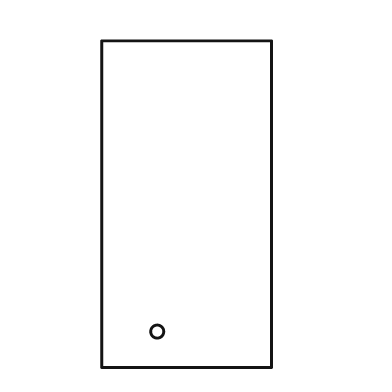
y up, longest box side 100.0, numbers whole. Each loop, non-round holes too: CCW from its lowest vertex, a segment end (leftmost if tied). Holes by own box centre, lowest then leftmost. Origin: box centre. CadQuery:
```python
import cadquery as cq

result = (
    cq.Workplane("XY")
    .moveTo(-26.0, -50.0)
    .lineTo(26.0, -50.0)
    .lineTo(26.0, 50.0)
    .lineTo(-26.0, 50.0)
    .close()
    .moveTo(-9.0, -39.0)
    .circle(2.0)
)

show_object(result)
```